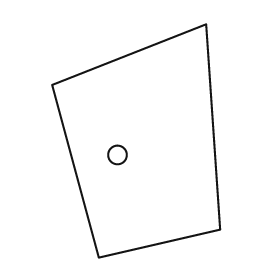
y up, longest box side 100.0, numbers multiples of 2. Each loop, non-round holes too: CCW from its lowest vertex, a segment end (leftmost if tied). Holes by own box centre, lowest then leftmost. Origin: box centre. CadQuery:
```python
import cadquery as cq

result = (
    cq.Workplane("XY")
    .moveTo(-16.0, -50.0)
    .lineTo(36.0, -38.0)
    .lineTo(30.0, 50.0)
    .lineTo(-36.0, 24.0)
    .close()
    .moveTo(-8.0, -6.0)
    .circle(4.0)
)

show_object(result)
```